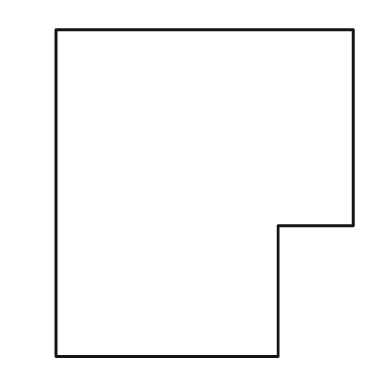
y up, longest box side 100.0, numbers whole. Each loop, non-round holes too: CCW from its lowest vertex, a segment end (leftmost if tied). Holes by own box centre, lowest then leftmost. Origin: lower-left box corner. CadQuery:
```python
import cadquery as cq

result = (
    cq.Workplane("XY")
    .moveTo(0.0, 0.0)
    .lineTo(68.0, 0.0)
    .lineTo(68.0, 40.0)
    .lineTo(91.0, 40.0)
    .lineTo(91.0, 100.0)
    .lineTo(0.0, 100.0)
    .close()
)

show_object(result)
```